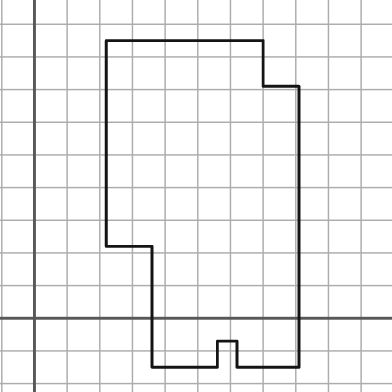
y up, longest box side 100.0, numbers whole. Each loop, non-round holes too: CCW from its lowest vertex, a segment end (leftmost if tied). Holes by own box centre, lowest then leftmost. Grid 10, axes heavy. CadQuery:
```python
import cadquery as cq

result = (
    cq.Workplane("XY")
    .moveTo(36.0, -15.0)
    .lineTo(56.0, -15.0)
    .lineTo(56.0, -7.0)
    .lineTo(62.0, -7.0)
    .lineTo(62.0, -15.0)
    .lineTo(81.0, -15.0)
    .lineTo(81.0, 71.0)
    .lineTo(70.0, 71.0)
    .lineTo(70.0, 85.0)
    .lineTo(22.0, 85.0)
    .lineTo(22.0, 22.0)
    .lineTo(36.0, 22.0)
    .close()
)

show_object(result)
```